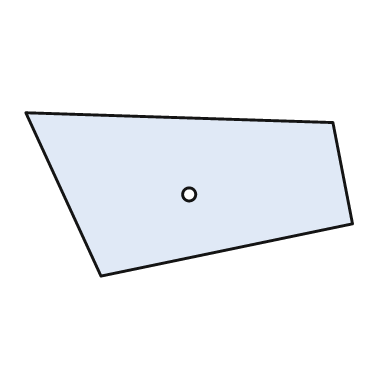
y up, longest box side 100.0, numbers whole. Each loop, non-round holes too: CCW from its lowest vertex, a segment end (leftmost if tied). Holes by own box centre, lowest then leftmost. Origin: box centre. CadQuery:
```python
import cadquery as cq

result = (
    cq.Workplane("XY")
    .moveTo(-27.0, -25.0)
    .lineTo(50.0, -9.0)
    .lineTo(44.0, 22.0)
    .lineTo(-50.0, 25.0)
    .close()
    .moveTo(0.0, 0.0)
    .circle(2.0)
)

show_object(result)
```